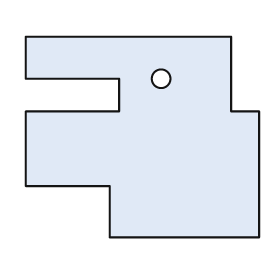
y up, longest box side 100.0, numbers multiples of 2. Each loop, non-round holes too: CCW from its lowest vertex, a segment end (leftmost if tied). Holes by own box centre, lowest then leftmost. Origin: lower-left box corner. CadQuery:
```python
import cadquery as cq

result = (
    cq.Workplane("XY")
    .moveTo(36.0, 0.0)
    .lineTo(100.0, 0.0)
    .lineTo(100.0, 54.0)
    .lineTo(88.0, 54.0)
    .lineTo(88.0, 86.0)
    .lineTo(0.0, 86.0)
    .lineTo(0.0, 68.0)
    .lineTo(40.0, 68.0)
    .lineTo(40.0, 54.0)
    .lineTo(0.0, 54.0)
    .lineTo(0.0, 22.0)
    .lineTo(36.0, 22.0)
    .close()
    .moveTo(58.0, 68.0)
    .circle(4.0)
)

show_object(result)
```